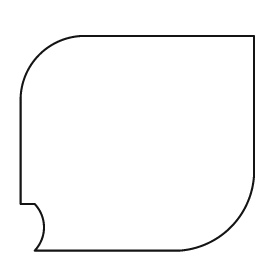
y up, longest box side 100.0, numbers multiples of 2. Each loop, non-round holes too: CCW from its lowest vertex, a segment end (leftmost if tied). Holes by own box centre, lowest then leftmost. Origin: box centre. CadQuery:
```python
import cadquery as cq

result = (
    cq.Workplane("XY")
    .moveTo(-44.0, -46.0)
    .lineTo(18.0, -46.0)
    .threePointArc((40.0, -36.0), (50.0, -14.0))
    .lineTo(50.0, 46.0)
    .lineTo(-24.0, 46.0)
    .threePointArc((-42.0, 38.0), (-50.0, 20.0))
    .lineTo(-50.0, -26.0)
    .lineTo(-44.0, -26.0)
    .threePointArc((-40.0, -36.0), (-44.0, -46.0))
    .close()
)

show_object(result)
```